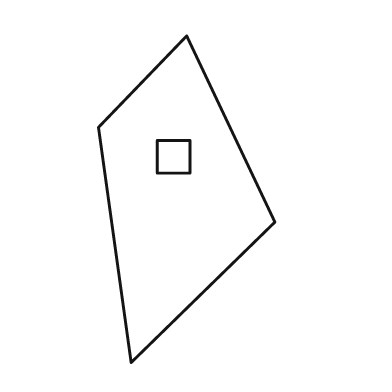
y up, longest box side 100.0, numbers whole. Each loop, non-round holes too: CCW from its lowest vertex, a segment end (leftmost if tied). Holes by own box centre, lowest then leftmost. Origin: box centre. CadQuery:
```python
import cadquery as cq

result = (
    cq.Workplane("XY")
    .moveTo(-17.0, -50.0)
    .lineTo(27.0, -7.0)
    .lineTo(0.0, 50.0)
    .lineTo(-27.0, 22.0)
    .close()
    .moveTo(-9.0, 8.0)
    .lineTo(1.0, 8.0)
    .lineTo(1.0, 18.0)
    .lineTo(-9.0, 18.0)
    .close()
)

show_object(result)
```